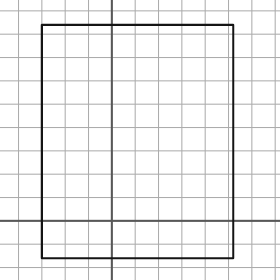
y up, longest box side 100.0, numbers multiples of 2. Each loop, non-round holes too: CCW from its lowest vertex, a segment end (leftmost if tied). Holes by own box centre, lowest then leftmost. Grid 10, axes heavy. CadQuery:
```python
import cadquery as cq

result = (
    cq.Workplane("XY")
    .moveTo(-30.0, -16.0)
    .lineTo(52.0, -16.0)
    .lineTo(52.0, 84.0)
    .lineTo(-30.0, 84.0)
    .close()
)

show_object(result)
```